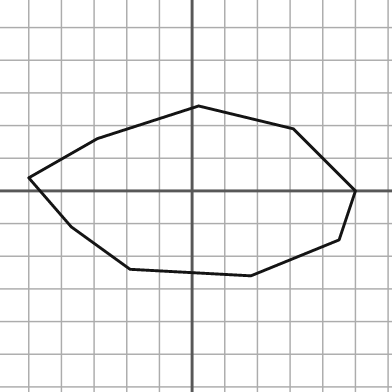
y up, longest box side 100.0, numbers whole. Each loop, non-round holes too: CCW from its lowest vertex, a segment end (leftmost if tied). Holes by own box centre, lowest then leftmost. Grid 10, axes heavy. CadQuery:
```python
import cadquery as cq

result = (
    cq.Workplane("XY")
    .moveTo(18.0, -26.0)
    .lineTo(45.0, -15.0)
    .lineTo(50.0, 0.0)
    .lineTo(31.0, 19.0)
    .lineTo(2.0, 26.0)
    .lineTo(-29.0, 16.0)
    .lineTo(-50.0, 4.0)
    .lineTo(-37.0, -11.0)
    .lineTo(-19.0, -24.0)
    .close()
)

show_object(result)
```